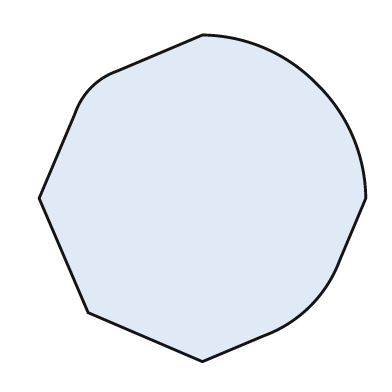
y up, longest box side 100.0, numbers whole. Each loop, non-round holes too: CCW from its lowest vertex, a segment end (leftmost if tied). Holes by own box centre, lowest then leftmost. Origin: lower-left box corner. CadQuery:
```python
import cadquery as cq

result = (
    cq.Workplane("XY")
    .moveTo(50.0, 0.0)
    .lineTo(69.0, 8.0)
    .threePointArc((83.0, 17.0), (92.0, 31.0))
    .lineTo(100.0, 50.0)
    .threePointArc((96.0, 69.0), (85.0, 85.0))
    .threePointArc((69.0, 96.0), (50.0, 100.0))
    .lineTo(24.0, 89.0)
    .threePointArc((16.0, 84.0), (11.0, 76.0))
    .lineTo(0.0, 50.0)
    .lineTo(15.0, 15.0)
    .close()
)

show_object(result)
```